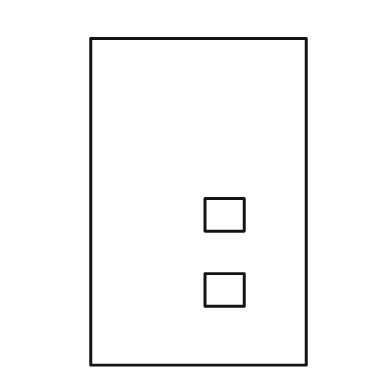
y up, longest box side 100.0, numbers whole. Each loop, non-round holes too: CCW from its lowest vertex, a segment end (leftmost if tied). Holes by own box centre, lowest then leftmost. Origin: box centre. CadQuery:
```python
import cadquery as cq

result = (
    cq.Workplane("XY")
    .moveTo(-33.0, -50.0)
    .lineTo(33.0, -50.0)
    .lineTo(33.0, 50.0)
    .lineTo(-33.0, 50.0)
    .close()
    .moveTo(2.0, -32.0)
    .lineTo(14.0, -32.0)
    .lineTo(14.0, -22.0)
    .lineTo(2.0, -22.0)
    .close()
    .moveTo(2.0, -9.0)
    .lineTo(14.0, -9.0)
    .lineTo(14.0, 1.0)
    .lineTo(2.0, 1.0)
    .close()
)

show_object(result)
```